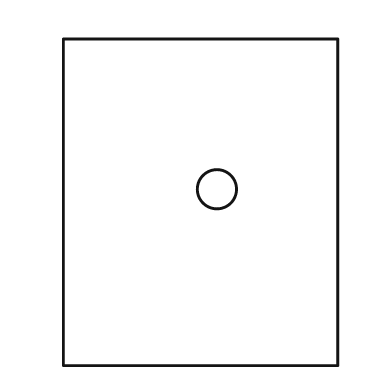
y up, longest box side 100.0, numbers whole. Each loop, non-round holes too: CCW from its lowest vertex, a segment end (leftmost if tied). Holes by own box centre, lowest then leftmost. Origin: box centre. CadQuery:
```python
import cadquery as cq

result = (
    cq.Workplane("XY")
    .moveTo(-42.0, -50.0)
    .lineTo(42.0, -50.0)
    .lineTo(42.0, 50.0)
    .lineTo(-42.0, 50.0)
    .close()
    .moveTo(5.0, 4.0)
    .circle(6.0)
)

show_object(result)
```